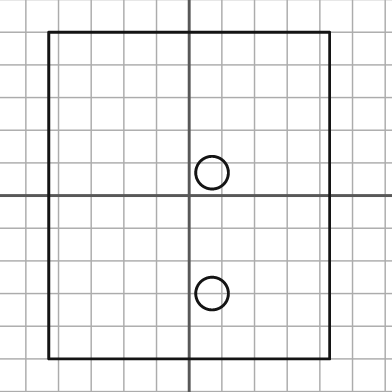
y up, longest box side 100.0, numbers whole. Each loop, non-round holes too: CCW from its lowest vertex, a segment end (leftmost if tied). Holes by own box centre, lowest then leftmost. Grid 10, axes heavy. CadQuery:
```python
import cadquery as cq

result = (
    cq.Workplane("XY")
    .moveTo(-43.0, -50.0)
    .lineTo(43.0, -50.0)
    .lineTo(43.0, 50.0)
    .lineTo(-43.0, 50.0)
    .close()
    .moveTo(7.0, -30.0)
    .circle(5.0)
    .moveTo(7.0, 7.0)
    .circle(5.0)
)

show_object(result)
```